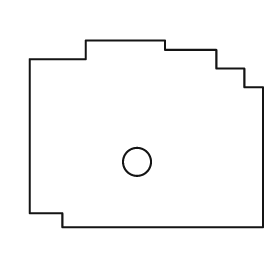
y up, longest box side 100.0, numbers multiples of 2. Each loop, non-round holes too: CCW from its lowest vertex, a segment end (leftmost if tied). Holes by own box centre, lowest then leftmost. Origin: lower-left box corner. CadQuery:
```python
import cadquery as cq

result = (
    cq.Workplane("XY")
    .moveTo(14.0, 0.0)
    .lineTo(100.0, 0.0)
    .lineTo(100.0, 60.0)
    .lineTo(92.0, 60.0)
    .lineTo(92.0, 68.0)
    .lineTo(80.0, 68.0)
    .lineTo(80.0, 76.0)
    .lineTo(58.0, 76.0)
    .lineTo(58.0, 80.0)
    .lineTo(24.0, 80.0)
    .lineTo(24.0, 72.0)
    .lineTo(0.0, 72.0)
    .lineTo(0.0, 6.0)
    .lineTo(14.0, 6.0)
    .close()
    .moveTo(46.0, 28.0)
    .circle(6.0)
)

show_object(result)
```